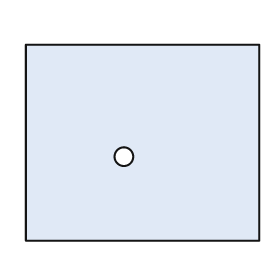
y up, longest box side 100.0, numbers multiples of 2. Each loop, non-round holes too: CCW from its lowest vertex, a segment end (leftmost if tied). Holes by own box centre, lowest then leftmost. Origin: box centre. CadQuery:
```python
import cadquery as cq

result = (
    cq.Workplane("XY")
    .moveTo(-50.0, -42.0)
    .lineTo(50.0, -42.0)
    .lineTo(50.0, 42.0)
    .lineTo(-50.0, 42.0)
    .close()
    .moveTo(-8.0, -6.0)
    .circle(4.0)
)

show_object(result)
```